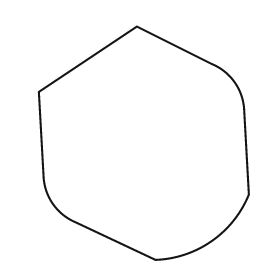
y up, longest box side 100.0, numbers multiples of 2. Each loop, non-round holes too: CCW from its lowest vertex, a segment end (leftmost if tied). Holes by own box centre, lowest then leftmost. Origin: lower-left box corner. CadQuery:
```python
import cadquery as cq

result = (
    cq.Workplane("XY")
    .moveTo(50.0, 0.0)
    .threePointArc((74.0, 8.0), (90.0, 28.0))
    .lineTo(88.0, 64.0)
    .threePointArc((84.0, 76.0), (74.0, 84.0))
    .lineTo(42.0, 100.0)
    .lineTo(0.0, 72.0)
    .lineTo(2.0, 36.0)
    .threePointArc((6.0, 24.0), (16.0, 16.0))
    .close()
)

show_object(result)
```